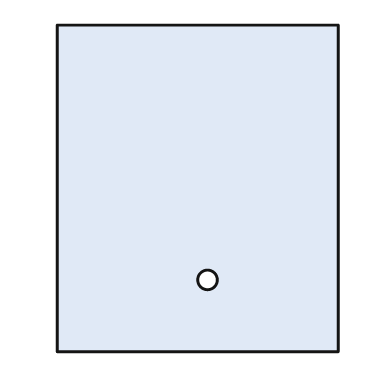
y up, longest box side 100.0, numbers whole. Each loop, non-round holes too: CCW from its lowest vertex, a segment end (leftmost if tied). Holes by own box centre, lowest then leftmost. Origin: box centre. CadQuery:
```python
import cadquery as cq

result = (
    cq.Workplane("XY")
    .moveTo(-43.0, -50.0)
    .lineTo(43.0, -50.0)
    .lineTo(43.0, 50.0)
    .lineTo(-43.0, 50.0)
    .close()
    .moveTo(3.0, -28.0)
    .circle(3.0)
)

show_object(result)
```